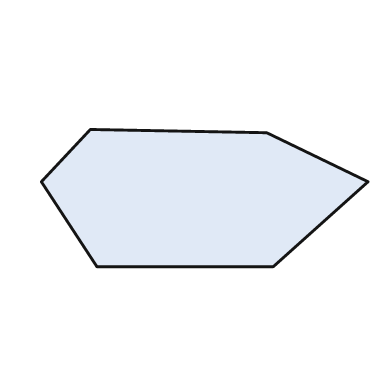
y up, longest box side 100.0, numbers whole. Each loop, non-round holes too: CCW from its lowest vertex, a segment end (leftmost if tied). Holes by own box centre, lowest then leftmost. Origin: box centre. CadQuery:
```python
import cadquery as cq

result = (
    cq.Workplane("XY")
    .moveTo(-33.0, -21.0)
    .lineTo(21.0, -21.0)
    .lineTo(50.0, 5.0)
    .lineTo(19.0, 20.0)
    .lineTo(-35.0, 21.0)
    .lineTo(-50.0, 5.0)
    .close()
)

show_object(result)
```